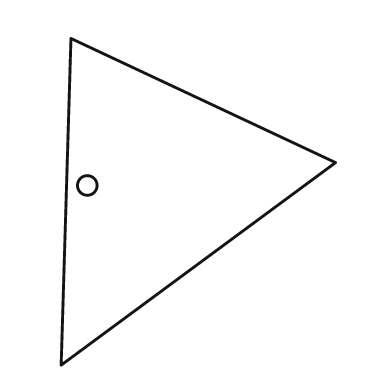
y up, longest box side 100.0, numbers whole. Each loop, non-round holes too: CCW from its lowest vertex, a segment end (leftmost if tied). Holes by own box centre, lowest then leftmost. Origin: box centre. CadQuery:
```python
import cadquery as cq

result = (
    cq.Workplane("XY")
    .moveTo(-42.0, -50.0)
    .lineTo(42.0, 12.0)
    .lineTo(-39.0, 50.0)
    .close()
    .moveTo(-34.0, 5.0)
    .circle(3.0)
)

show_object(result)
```